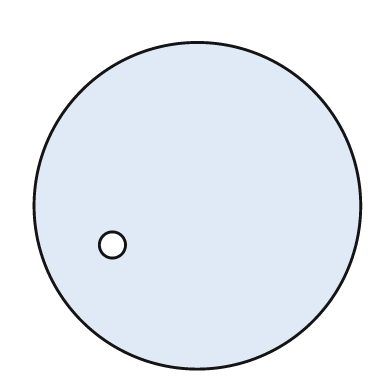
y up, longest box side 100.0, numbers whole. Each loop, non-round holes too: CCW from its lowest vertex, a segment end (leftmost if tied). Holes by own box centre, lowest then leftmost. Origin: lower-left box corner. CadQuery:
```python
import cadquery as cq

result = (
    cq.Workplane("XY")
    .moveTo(50.0, 50.0)
    .circle(50.0)
    .moveTo(24.0, 38.0)
    .circle(4.0)
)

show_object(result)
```